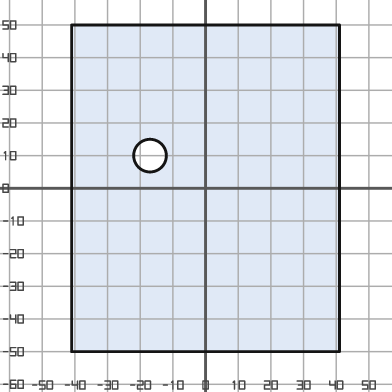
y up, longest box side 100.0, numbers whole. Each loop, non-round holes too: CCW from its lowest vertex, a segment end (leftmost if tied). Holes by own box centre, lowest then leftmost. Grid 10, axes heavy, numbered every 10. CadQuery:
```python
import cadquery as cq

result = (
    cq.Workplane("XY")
    .moveTo(-41.0, -50.0)
    .lineTo(41.0, -50.0)
    .lineTo(41.0, 50.0)
    .lineTo(-41.0, 50.0)
    .close()
    .moveTo(-17.0, 10.0)
    .circle(5.0)
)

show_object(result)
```